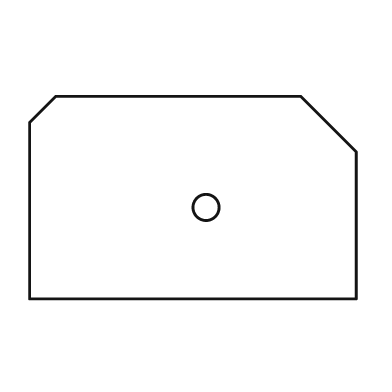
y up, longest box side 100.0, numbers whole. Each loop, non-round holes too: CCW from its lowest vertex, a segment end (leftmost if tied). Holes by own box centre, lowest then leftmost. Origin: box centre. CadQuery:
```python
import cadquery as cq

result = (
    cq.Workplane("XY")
    .moveTo(-50.0, -31.0)
    .lineTo(50.0, -31.0)
    .lineTo(50.0, 14.0)
    .lineTo(33.0, 31.0)
    .lineTo(-42.0, 31.0)
    .lineTo(-50.0, 23.0)
    .close()
    .moveTo(4.0, -3.0)
    .circle(4.0)
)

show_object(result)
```